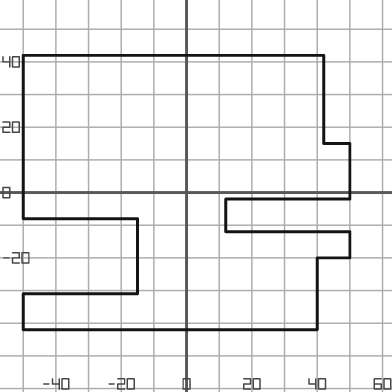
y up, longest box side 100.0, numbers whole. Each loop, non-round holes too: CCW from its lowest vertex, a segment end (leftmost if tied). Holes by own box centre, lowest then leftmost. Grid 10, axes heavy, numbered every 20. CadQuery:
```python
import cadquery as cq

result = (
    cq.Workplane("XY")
    .moveTo(-50.0, -42.0)
    .lineTo(40.0, -42.0)
    .lineTo(40.0, -20.0)
    .lineTo(50.0, -20.0)
    .lineTo(50.0, -12.0)
    .lineTo(12.0, -12.0)
    .lineTo(12.0, -2.0)
    .lineTo(50.0, -2.0)
    .lineTo(50.0, 15.0)
    .lineTo(42.0, 15.0)
    .lineTo(42.0, 42.0)
    .lineTo(-50.0, 42.0)
    .lineTo(-50.0, -8.0)
    .lineTo(-15.0, -8.0)
    .lineTo(-15.0, -31.0)
    .lineTo(-50.0, -31.0)
    .close()
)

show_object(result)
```